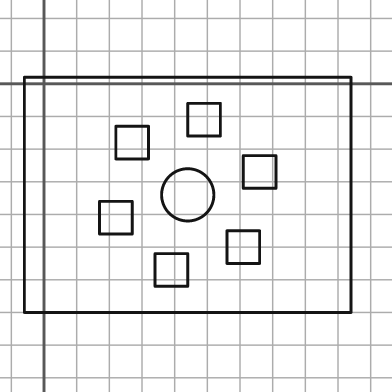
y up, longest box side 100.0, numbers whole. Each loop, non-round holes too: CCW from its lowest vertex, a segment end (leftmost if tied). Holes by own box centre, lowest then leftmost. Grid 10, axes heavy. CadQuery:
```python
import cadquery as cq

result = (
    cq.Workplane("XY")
    .moveTo(-6.0, -70.0)
    .lineTo(94.0, -70.0)
    .lineTo(94.0, 2.0)
    .lineTo(-6.0, 2.0)
    .close()
    .moveTo(34.0, -62.0)
    .lineTo(44.0, -62.0)
    .lineTo(44.0, -52.0)
    .lineTo(34.0, -52.0)
    .close()
    .moveTo(56.0, -55.0)
    .lineTo(66.0, -55.0)
    .lineTo(66.0, -45.0)
    .lineTo(56.0, -45.0)
    .close()
    .moveTo(17.0, -46.0)
    .lineTo(27.0, -46.0)
    .lineTo(27.0, -36.0)
    .lineTo(17.0, -36.0)
    .close()
    .moveTo(44.0, -34.0)
    .circle(8.0)
    .moveTo(61.0, -32.0)
    .lineTo(71.0, -32.0)
    .lineTo(71.0, -22.0)
    .lineTo(61.0, -22.0)
    .close()
    .moveTo(22.0, -23.0)
    .lineTo(32.0, -23.0)
    .lineTo(32.0, -13.0)
    .lineTo(22.0, -13.0)
    .close()
    .moveTo(44.0, -16.0)
    .lineTo(54.0, -16.0)
    .lineTo(54.0, -6.0)
    .lineTo(44.0, -6.0)
    .close()
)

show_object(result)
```